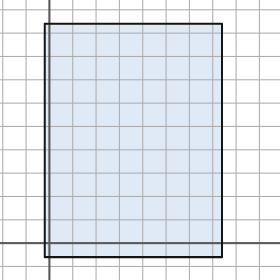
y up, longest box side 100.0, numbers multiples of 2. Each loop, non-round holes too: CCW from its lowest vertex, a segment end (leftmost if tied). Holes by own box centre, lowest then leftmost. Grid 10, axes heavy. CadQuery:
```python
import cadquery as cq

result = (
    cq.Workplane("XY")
    .moveTo(-2.0, -6.0)
    .lineTo(74.0, -6.0)
    .lineTo(74.0, 94.0)
    .lineTo(-2.0, 94.0)
    .close()
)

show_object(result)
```